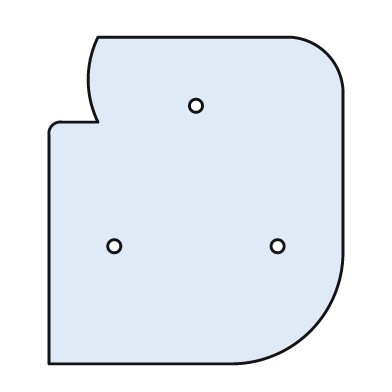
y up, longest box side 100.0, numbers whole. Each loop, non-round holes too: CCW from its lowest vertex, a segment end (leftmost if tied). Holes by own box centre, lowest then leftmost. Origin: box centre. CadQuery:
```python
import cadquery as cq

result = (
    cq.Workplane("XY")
    .moveTo(-45.0, -50.0)
    .lineTo(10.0, -50.0)
    .threePointArc((35.0, -40.0), (45.0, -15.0))
    .lineTo(45.0, 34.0)
    .threePointArc((40.0, 45.0), (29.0, 50.0))
    .lineTo(-30.0, 50.0)
    .threePointArc((-33.0, 37.0), (-30.0, 24.0))
    .lineTo(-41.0, 24.0)
    .threePointArc((-44.0, 23.0), (-45.0, 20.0))
    .close()
    .moveTo(-25.0, -14.0)
    .circle(2.0)
    .moveTo(25.0, -14.0)
    .circle(2.0)
    .moveTo(0.0, 29.0)
    .circle(2.0)
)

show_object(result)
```